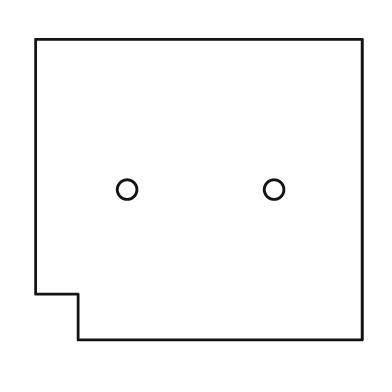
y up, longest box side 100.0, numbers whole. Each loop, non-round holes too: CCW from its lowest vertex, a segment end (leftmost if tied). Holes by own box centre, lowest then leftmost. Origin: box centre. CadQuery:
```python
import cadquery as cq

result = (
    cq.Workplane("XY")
    .moveTo(-37.0, -46.0)
    .lineTo(50.0, -46.0)
    .lineTo(50.0, 46.0)
    .lineTo(-50.0, 46.0)
    .lineTo(-50.0, -32.0)
    .lineTo(-37.0, -32.0)
    .close()
    .moveTo(-22.0, 0.0)
    .circle(3.0)
    .moveTo(23.0, 0.0)
    .circle(3.0)
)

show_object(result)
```